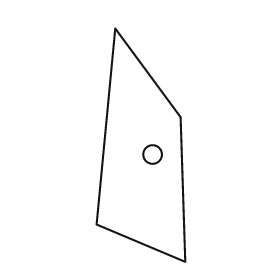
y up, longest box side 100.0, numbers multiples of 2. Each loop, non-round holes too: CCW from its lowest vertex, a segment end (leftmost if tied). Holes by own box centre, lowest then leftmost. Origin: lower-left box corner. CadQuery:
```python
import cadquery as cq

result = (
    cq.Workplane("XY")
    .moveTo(38.0, 0.0)
    .lineTo(36.0, 62.0)
    .lineTo(8.0, 100.0)
    .lineTo(0.0, 16.0)
    .close()
    .moveTo(24.0, 46.0)
    .circle(4.0)
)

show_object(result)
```